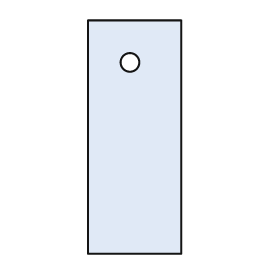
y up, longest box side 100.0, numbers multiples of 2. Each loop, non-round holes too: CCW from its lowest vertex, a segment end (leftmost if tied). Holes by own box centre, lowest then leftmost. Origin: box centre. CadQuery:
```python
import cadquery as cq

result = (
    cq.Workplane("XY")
    .moveTo(-20.0, -50.0)
    .lineTo(20.0, -50.0)
    .lineTo(20.0, 50.0)
    .lineTo(-20.0, 50.0)
    .close()
    .moveTo(-2.0, 32.0)
    .circle(4.0)
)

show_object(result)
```